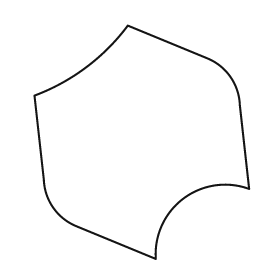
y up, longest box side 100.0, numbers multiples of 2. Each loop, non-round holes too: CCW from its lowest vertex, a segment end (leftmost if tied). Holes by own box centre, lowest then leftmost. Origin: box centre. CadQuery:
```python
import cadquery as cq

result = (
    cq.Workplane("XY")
    .moveTo(6.0, -50.0)
    .threePointArc((18.0, -24.0), (46.0, -20.0))
    .lineTo(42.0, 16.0)
    .threePointArc((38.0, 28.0), (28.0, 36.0))
    .lineTo(-6.0, 50.0)
    .threePointArc((-24.0, 32.0), (-46.0, 20.0))
    .lineTo(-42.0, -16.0)
    .threePointArc((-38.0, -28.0), (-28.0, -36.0))
    .close()
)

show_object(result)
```